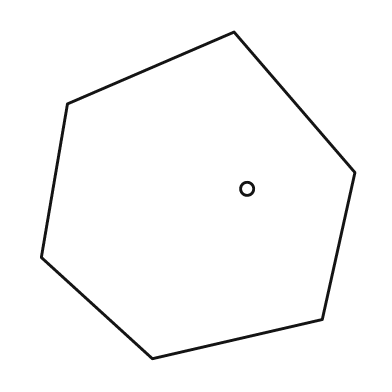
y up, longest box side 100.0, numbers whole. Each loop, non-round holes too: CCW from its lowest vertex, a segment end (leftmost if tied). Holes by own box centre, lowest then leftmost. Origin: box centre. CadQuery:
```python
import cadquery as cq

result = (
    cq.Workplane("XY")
    .moveTo(-14.0, -50.0)
    .lineTo(38.0, -38.0)
    .lineTo(48.0, 7.0)
    .lineTo(11.0, 50.0)
    .lineTo(-40.0, 28.0)
    .lineTo(-48.0, -19.0)
    .close()
    .moveTo(15.0, 2.0)
    .circle(2.0)
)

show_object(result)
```